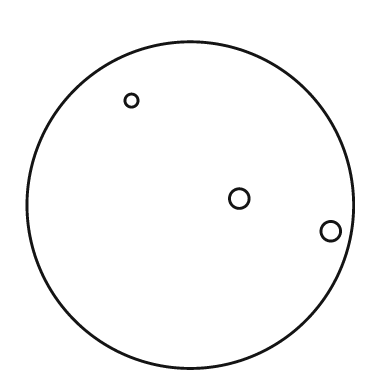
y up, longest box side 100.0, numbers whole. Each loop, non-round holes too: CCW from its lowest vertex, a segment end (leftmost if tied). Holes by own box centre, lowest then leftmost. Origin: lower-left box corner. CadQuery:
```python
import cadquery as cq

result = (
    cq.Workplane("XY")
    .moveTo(50.0, 50.0)
    .circle(50.0)
    .moveTo(93.0, 42.0)
    .circle(3.0)
    .moveTo(65.0, 52.0)
    .circle(3.0)
    .moveTo(32.0, 82.0)
    .circle(2.0)
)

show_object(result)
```